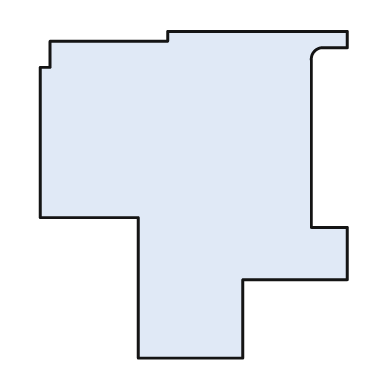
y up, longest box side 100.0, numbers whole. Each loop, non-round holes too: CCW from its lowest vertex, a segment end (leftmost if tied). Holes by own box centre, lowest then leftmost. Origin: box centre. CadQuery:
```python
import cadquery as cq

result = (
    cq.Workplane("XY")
    .moveTo(-17.0, -50.0)
    .lineTo(15.0, -50.0)
    .lineTo(15.0, -26.0)
    .lineTo(47.0, -26.0)
    .lineTo(47.0, -10.0)
    .lineTo(36.0, -10.0)
    .lineTo(36.0, 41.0)
    .threePointArc((37.0, 44.0), (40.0, 45.0))
    .lineTo(47.0, 45.0)
    .lineTo(47.0, 50.0)
    .lineTo(-8.0, 50.0)
    .lineTo(-8.0, 47.0)
    .lineTo(-44.0, 47.0)
    .lineTo(-44.0, 39.0)
    .lineTo(-47.0, 39.0)
    .lineTo(-47.0, -7.0)
    .lineTo(-17.0, -7.0)
    .close()
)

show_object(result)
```